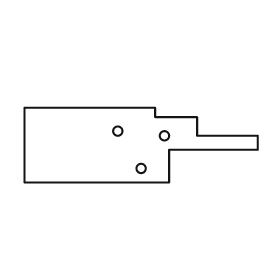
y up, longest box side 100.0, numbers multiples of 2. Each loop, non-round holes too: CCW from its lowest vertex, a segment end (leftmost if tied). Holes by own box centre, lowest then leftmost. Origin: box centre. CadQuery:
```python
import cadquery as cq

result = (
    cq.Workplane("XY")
    .moveTo(-50.0, -16.0)
    .lineTo(12.0, -16.0)
    .lineTo(12.0, -2.0)
    .lineTo(50.0, -2.0)
    .lineTo(50.0, 4.0)
    .lineTo(24.0, 4.0)
    .lineTo(24.0, 12.0)
    .lineTo(6.0, 12.0)
    .lineTo(6.0, 16.0)
    .lineTo(-50.0, 16.0)
    .close()
    .moveTo(0.0, -10.0)
    .circle(2.0)
    .moveTo(10.0, 4.0)
    .circle(2.0)
    .moveTo(-10.0, 6.0)
    .circle(2.0)
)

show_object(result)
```